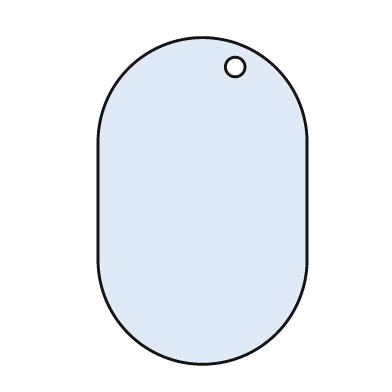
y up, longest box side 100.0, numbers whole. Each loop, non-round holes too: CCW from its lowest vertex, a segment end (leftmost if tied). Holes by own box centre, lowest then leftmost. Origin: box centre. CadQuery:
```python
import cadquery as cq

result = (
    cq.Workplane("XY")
    .moveTo(-32.0, -18.0)
    .threePointArc((0.0, -50.0), (32.0, -18.0))
    .lineTo(32.0, 18.0)
    .threePointArc((0.0, 50.0), (-32.0, 18.0))
    .close()
    .moveTo(10.0, 41.0)
    .circle(3.0)
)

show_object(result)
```